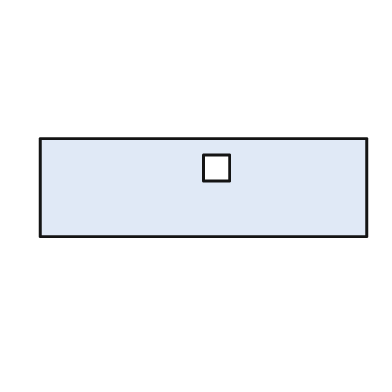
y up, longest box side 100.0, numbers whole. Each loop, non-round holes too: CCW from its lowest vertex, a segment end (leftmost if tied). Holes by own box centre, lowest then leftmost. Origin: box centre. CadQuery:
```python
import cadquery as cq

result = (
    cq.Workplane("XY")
    .moveTo(-50.0, -15.0)
    .lineTo(50.0, -15.0)
    .lineTo(50.0, 15.0)
    .lineTo(-50.0, 15.0)
    .close()
    .moveTo(0.0, 2.0)
    .lineTo(8.0, 2.0)
    .lineTo(8.0, 10.0)
    .lineTo(0.0, 10.0)
    .close()
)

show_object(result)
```